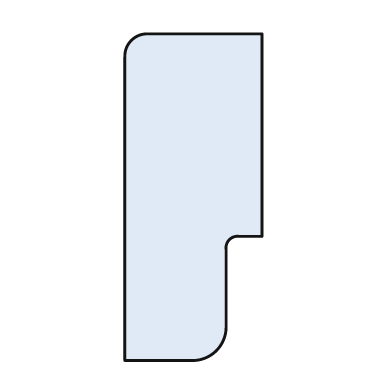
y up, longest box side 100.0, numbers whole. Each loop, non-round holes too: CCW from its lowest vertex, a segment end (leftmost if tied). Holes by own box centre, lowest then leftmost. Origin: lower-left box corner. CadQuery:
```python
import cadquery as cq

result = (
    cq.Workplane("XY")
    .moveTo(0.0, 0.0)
    .lineTo(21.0, 0.0)
    .threePointArc((28.0, 3.0), (31.0, 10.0))
    .lineTo(31.0, 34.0)
    .threePointArc((32.0, 37.0), (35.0, 38.0))
    .lineTo(42.0, 38.0)
    .lineTo(42.0, 100.0)
    .lineTo(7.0, 100.0)
    .threePointArc((2.0, 98.0), (0.0, 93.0))
    .close()
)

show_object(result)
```